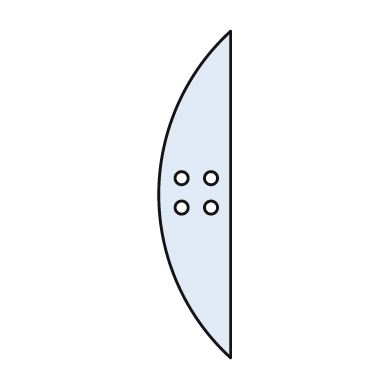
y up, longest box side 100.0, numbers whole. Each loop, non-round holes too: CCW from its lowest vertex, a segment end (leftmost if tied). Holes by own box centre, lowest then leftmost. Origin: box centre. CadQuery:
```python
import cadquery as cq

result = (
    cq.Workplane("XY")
    .moveTo(11.0, -50.0)
    .lineTo(11.0, 50.0)
    .threePointArc((-11.0, 0.0), (11.0, -50.0))
    .close()
    .moveTo(-4.0, -4.0)
    .circle(2.0)
    .moveTo(5.0, -4.0)
    .circle(2.0)
    .moveTo(-4.0, 5.0)
    .circle(2.0)
    .moveTo(5.0, 5.0)
    .circle(2.0)
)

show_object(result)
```